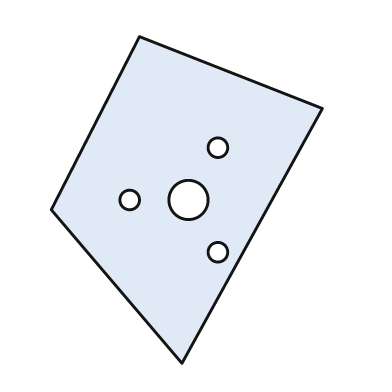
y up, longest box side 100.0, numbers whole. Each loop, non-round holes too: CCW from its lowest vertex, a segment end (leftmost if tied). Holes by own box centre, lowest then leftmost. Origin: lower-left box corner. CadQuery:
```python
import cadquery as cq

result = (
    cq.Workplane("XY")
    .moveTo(40.0, 0.0)
    .lineTo(83.0, 78.0)
    .lineTo(27.0, 100.0)
    .lineTo(0.0, 47.0)
    .close()
    .moveTo(51.0, 34.0)
    .circle(3.0)
    .moveTo(24.0, 50.0)
    .circle(3.0)
    .moveTo(42.0, 50.0)
    .circle(6.0)
    .moveTo(51.0, 66.0)
    .circle(3.0)
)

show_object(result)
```